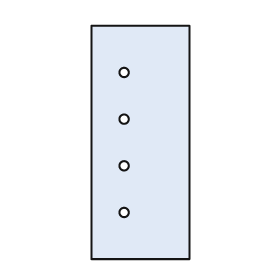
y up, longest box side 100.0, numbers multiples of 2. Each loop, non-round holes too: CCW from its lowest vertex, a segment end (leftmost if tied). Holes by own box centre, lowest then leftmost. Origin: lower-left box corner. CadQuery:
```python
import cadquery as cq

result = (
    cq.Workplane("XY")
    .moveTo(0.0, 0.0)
    .lineTo(42.0, 0.0)
    .lineTo(42.0, 100.0)
    .lineTo(0.0, 100.0)
    .close()
    .moveTo(14.0, 20.0)
    .circle(2.0)
    .moveTo(14.0, 40.0)
    .circle(2.0)
    .moveTo(14.0, 60.0)
    .circle(2.0)
    .moveTo(14.0, 80.0)
    .circle(2.0)
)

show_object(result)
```